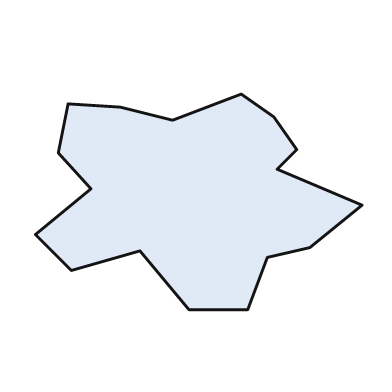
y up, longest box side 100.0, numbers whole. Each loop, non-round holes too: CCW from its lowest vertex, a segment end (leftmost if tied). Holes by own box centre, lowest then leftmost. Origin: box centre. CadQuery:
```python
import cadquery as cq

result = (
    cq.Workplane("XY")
    .moveTo(-3.0, -33.0)
    .lineTo(15.0, -33.0)
    .lineTo(21.0, -17.0)
    .lineTo(34.0, -14.0)
    .lineTo(50.0, -1.0)
    .lineTo(24.0, 10.0)
    .lineTo(30.0, 16.0)
    .lineTo(23.0, 26.0)
    .lineTo(13.0, 33.0)
    .lineTo(-8.0, 25.0)
    .lineTo(-24.0, 29.0)
    .lineTo(-40.0, 30.0)
    .lineTo(-43.0, 15.0)
    .lineTo(-33.0, 4.0)
    .lineTo(-50.0, -10.0)
    .lineTo(-39.0, -21.0)
    .lineTo(-18.0, -15.0)
    .close()
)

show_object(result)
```